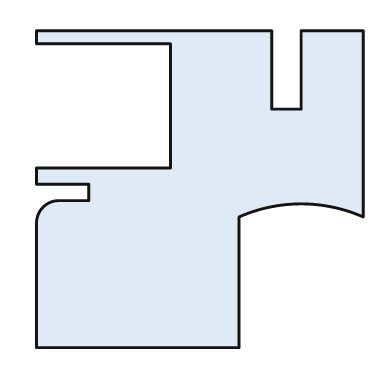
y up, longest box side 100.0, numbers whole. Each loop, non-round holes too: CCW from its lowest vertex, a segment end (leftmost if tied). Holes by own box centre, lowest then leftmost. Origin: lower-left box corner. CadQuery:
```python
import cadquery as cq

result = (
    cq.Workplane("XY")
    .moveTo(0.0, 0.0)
    .lineTo(62.0, 0.0)
    .lineTo(62.0, 40.0)
    .threePointArc((81.0, 44.0), (100.0, 40.0))
    .lineTo(100.0, 97.0)
    .lineTo(81.0, 97.0)
    .lineTo(81.0, 73.0)
    .lineTo(72.0, 73.0)
    .lineTo(72.0, 97.0)
    .lineTo(0.0, 97.0)
    .lineTo(0.0, 93.0)
    .lineTo(41.0, 93.0)
    .lineTo(41.0, 55.0)
    .lineTo(0.0, 55.0)
    .lineTo(0.0, 50.0)
    .lineTo(16.0, 50.0)
    .lineTo(16.0, 45.0)
    .lineTo(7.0, 45.0)
    .threePointArc((2.0, 43.0), (0.0, 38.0))
    .close()
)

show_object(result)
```